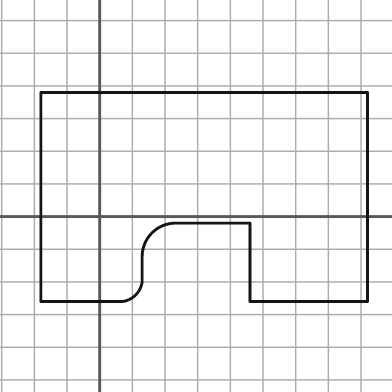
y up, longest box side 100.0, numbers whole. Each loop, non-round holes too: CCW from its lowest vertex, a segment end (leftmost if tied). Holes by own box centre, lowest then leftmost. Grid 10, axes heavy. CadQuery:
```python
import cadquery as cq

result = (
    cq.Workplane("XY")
    .moveTo(-18.0, -26.0)
    .lineTo(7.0, -26.0)
    .threePointArc((11.0, -24.0), (13.0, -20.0))
    .lineTo(13.0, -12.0)
    .threePointArc((16.0, -5.0), (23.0, -2.0))
    .lineTo(46.0, -2.0)
    .lineTo(46.0, -26.0)
    .lineTo(82.0, -26.0)
    .lineTo(82.0, 38.0)
    .lineTo(-18.0, 38.0)
    .close()
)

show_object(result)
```